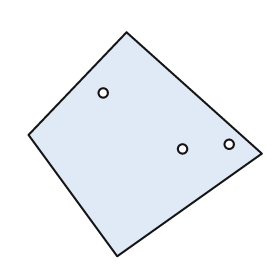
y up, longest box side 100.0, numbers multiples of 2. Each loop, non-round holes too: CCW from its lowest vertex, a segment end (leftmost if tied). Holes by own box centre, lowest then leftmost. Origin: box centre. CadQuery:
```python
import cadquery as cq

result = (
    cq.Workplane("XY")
    .moveTo(-12.0, -48.0)
    .lineTo(50.0, -4.0)
    .lineTo(-8.0, 48.0)
    .lineTo(-50.0, 4.0)
    .close()
    .moveTo(16.0, -2.0)
    .circle(2.0)
    .moveTo(36.0, 0.0)
    .circle(2.0)
    .moveTo(-18.0, 22.0)
    .circle(2.0)
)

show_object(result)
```